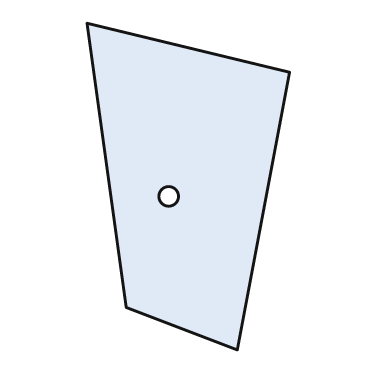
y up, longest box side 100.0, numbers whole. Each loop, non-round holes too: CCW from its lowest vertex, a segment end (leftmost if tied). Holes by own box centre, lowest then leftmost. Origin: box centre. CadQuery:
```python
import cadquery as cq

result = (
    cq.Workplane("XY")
    .moveTo(15.0, -50.0)
    .lineTo(31.0, 35.0)
    .lineTo(-31.0, 50.0)
    .lineTo(-19.0, -37.0)
    .close()
    .moveTo(-6.0, -3.0)
    .circle(3.0)
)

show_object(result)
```